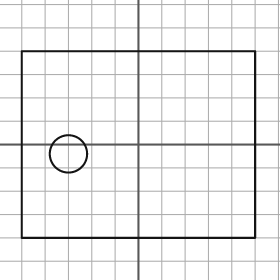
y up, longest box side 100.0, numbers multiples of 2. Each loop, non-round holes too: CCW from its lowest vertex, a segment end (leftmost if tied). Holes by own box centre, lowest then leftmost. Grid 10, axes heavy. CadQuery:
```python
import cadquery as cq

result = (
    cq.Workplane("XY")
    .moveTo(-50.0, -40.0)
    .lineTo(50.0, -40.0)
    .lineTo(50.0, 40.0)
    .lineTo(-50.0, 40.0)
    .close()
    .moveTo(-30.0, -4.0)
    .circle(8.0)
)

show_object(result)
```